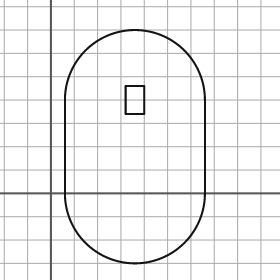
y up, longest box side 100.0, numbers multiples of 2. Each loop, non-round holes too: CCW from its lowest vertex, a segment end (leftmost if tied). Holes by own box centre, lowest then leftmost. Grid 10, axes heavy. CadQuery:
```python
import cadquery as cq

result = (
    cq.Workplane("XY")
    .moveTo(6.0, 0.0)
    .threePointArc((36.0, -30.0), (66.0, 0.0))
    .lineTo(66.0, 40.0)
    .threePointArc((36.0, 70.0), (6.0, 40.0))
    .close()
    .moveTo(32.0, 34.0)
    .lineTo(40.0, 34.0)
    .lineTo(40.0, 46.0)
    .lineTo(32.0, 46.0)
    .close()
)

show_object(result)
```